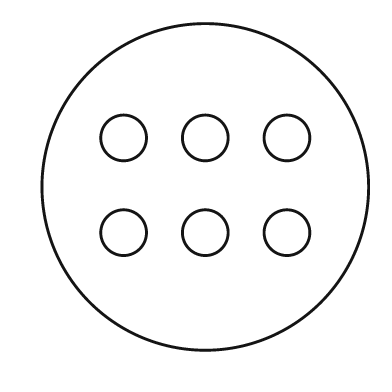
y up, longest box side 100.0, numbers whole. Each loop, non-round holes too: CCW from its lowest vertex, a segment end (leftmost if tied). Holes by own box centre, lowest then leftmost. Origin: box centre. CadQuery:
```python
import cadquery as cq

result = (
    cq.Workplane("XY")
    .moveTo(0.0, 0.0)
    .circle(50.0)
    .moveTo(-25.0, -14.0)
    .circle(7.0)
    .moveTo(0.0, -14.0)
    .circle(7.0)
    .moveTo(25.0, -14.0)
    .circle(7.0)
    .moveTo(-25.0, 15.0)
    .circle(7.0)
    .moveTo(0.0, 15.0)
    .circle(7.0)
    .moveTo(25.0, 15.0)
    .circle(7.0)
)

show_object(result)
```